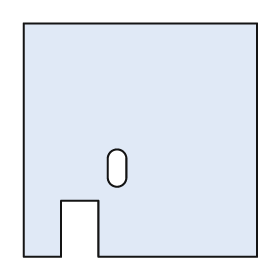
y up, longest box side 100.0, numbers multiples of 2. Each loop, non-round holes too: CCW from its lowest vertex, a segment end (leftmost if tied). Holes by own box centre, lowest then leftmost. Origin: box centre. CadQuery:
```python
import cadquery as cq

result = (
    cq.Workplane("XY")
    .moveTo(-50.0, -50.0)
    .lineTo(-34.0, -50.0)
    .lineTo(-34.0, -26.0)
    .lineTo(-18.0, -26.0)
    .lineTo(-18.0, -50.0)
    .lineTo(50.0, -50.0)
    .lineTo(50.0, 50.0)
    .lineTo(-50.0, 50.0)
    .close()
    .moveTo(-14.0, -16.0)
    .threePointArc((-10.0, -20.0), (-6.0, -16.0))
    .lineTo(-6.0, -8.0)
    .threePointArc((-10.0, -4.0), (-14.0, -8.0))
    .close()
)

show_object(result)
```